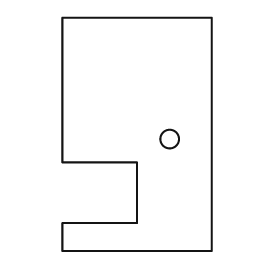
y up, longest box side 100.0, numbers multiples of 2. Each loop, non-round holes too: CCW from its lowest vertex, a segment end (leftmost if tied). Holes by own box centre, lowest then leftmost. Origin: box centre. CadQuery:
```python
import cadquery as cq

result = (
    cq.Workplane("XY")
    .moveTo(-32.0, -50.0)
    .lineTo(32.0, -50.0)
    .lineTo(32.0, 50.0)
    .lineTo(-32.0, 50.0)
    .lineTo(-32.0, -12.0)
    .lineTo(0.0, -12.0)
    .lineTo(0.0, -38.0)
    .lineTo(-32.0, -38.0)
    .close()
    .moveTo(14.0, -2.0)
    .circle(4.0)
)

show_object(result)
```